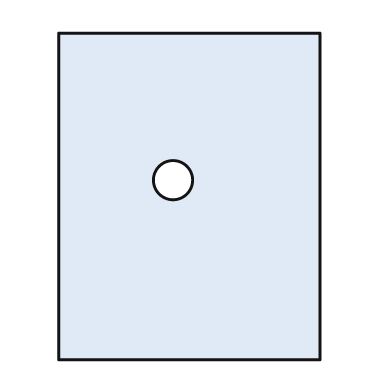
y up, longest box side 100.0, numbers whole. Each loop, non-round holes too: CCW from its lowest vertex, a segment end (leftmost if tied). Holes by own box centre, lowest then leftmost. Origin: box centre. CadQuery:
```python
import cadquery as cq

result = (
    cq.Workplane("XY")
    .moveTo(-40.0, -50.0)
    .lineTo(40.0, -50.0)
    .lineTo(40.0, 50.0)
    .lineTo(-40.0, 50.0)
    .close()
    .moveTo(-5.0, 5.0)
    .circle(6.0)
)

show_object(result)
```